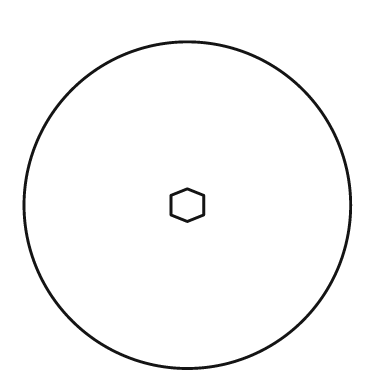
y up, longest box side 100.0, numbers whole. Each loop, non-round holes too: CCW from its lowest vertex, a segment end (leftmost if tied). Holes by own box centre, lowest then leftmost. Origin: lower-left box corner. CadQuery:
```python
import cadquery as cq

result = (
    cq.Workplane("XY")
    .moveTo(50.0, 50.0)
    .circle(50.0)
    .moveTo(50.0, 45.0)
    .lineTo(55.0, 47.0)
    .lineTo(55.0, 53.0)
    .lineTo(50.0, 55.0)
    .lineTo(45.0, 53.0)
    .lineTo(45.0, 47.0)
    .close()
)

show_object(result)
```